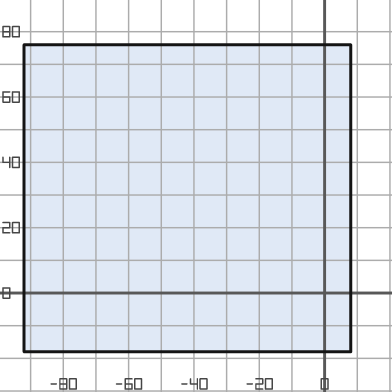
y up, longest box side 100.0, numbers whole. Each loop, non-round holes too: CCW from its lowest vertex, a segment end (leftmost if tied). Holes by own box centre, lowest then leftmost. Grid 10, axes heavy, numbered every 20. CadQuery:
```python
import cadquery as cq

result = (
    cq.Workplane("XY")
    .moveTo(-92.0, -18.0)
    .lineTo(8.0, -18.0)
    .lineTo(8.0, 76.0)
    .lineTo(-92.0, 76.0)
    .close()
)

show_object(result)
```